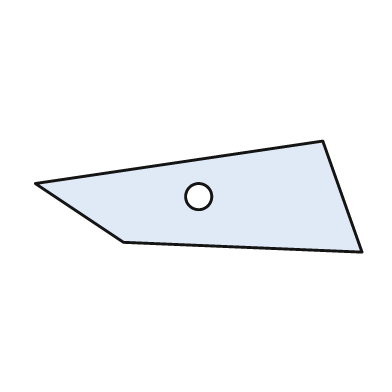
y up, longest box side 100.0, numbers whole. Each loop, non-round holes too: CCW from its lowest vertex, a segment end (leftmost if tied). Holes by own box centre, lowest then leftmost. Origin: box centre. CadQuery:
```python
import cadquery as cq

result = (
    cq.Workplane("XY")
    .moveTo(50.0, -17.0)
    .lineTo(38.0, 17.0)
    .lineTo(-50.0, 4.0)
    .lineTo(-23.0, -14.0)
    .close()
    .moveTo(0.0, 0.0)
    .circle(4.0)
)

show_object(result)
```